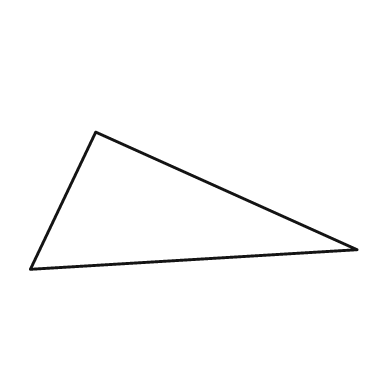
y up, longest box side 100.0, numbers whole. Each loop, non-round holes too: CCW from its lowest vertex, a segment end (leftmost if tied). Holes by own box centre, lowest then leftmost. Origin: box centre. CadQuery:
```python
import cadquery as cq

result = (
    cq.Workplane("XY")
    .moveTo(-50.0, -21.0)
    .lineTo(50.0, -15.0)
    .lineTo(-30.0, 21.0)
    .close()
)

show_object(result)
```